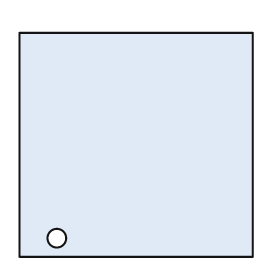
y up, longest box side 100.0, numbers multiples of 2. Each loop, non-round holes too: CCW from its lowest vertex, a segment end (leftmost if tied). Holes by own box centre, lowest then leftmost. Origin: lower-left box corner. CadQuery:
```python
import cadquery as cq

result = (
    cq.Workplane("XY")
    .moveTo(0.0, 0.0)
    .lineTo(100.0, 0.0)
    .lineTo(100.0, 96.0)
    .lineTo(0.0, 96.0)
    .close()
    .moveTo(16.0, 8.0)
    .circle(4.0)
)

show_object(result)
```